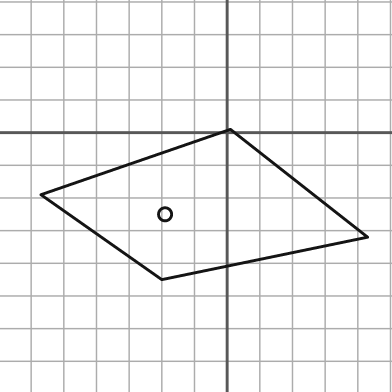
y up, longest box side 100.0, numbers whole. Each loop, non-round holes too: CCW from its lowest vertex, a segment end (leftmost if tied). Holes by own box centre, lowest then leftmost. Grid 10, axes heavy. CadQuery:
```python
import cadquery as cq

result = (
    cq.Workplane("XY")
    .moveTo(-20.0, -45.0)
    .lineTo(43.0, -32.0)
    .lineTo(1.0, 1.0)
    .lineTo(-57.0, -19.0)
    .close()
    .moveTo(-19.0, -25.0)
    .circle(2.0)
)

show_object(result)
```